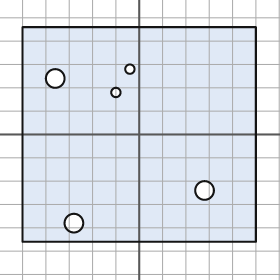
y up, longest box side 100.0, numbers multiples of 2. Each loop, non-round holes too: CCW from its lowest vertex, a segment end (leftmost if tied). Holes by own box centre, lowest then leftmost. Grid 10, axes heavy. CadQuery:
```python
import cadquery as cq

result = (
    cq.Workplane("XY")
    .moveTo(-50.0, -46.0)
    .lineTo(50.0, -46.0)
    .lineTo(50.0, 46.0)
    .lineTo(-50.0, 46.0)
    .close()
    .moveTo(-28.0, -38.0)
    .circle(4.0)
    .moveTo(28.0, -24.0)
    .circle(4.0)
    .moveTo(-10.0, 18.0)
    .circle(2.0)
    .moveTo(-36.0, 24.0)
    .circle(4.0)
    .moveTo(-4.0, 28.0)
    .circle(2.0)
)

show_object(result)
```